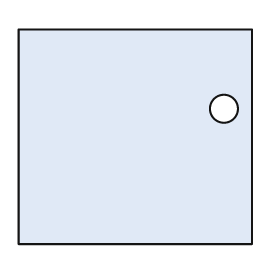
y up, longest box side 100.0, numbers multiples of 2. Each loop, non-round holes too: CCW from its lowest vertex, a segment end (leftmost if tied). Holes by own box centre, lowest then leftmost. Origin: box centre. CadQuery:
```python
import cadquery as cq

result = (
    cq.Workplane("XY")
    .moveTo(-50.0, -46.0)
    .lineTo(50.0, -46.0)
    .lineTo(50.0, 46.0)
    .lineTo(-50.0, 46.0)
    .close()
    .moveTo(38.0, 12.0)
    .circle(6.0)
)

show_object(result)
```